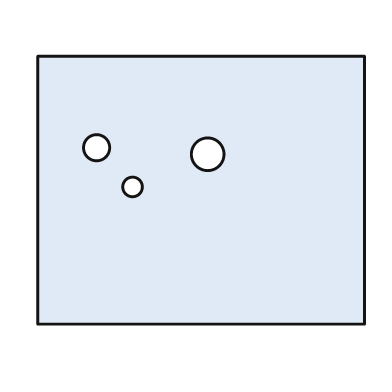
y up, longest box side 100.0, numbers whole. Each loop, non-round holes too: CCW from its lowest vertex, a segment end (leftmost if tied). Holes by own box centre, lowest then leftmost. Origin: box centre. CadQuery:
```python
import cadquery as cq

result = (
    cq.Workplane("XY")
    .moveTo(-50.0, -41.0)
    .lineTo(50.0, -41.0)
    .lineTo(50.0, 41.0)
    .lineTo(-50.0, 41.0)
    .close()
    .moveTo(-21.0, 1.0)
    .circle(3.0)
    .moveTo(2.0, 11.0)
    .circle(5.0)
    .moveTo(-32.0, 13.0)
    .circle(4.0)
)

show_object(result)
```